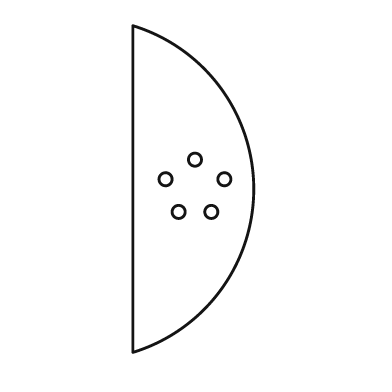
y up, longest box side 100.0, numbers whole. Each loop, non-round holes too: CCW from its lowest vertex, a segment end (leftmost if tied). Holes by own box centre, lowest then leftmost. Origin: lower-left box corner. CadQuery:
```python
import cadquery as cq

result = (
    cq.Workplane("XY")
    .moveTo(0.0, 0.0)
    .threePointArc((37.0, 50.0), (0.0, 100.0))
    .close()
    .moveTo(14.0, 43.0)
    .circle(2.0)
    .moveTo(24.0, 43.0)
    .circle(2.0)
    .moveTo(10.0, 53.0)
    .circle(2.0)
    .moveTo(28.0, 53.0)
    .circle(2.0)
    .moveTo(19.0, 59.0)
    .circle(2.0)
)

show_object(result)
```